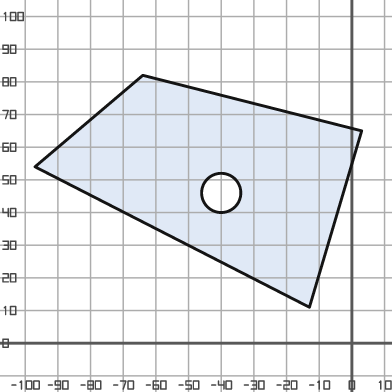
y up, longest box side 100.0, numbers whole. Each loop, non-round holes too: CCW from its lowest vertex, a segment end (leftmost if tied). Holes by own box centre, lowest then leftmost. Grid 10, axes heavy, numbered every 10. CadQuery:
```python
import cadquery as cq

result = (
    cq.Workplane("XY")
    .moveTo(-13.0, 11.0)
    .lineTo(3.0, 65.0)
    .lineTo(-64.0, 82.0)
    .lineTo(-97.0, 54.0)
    .close()
    .moveTo(-40.0, 46.0)
    .circle(6.0)
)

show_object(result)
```